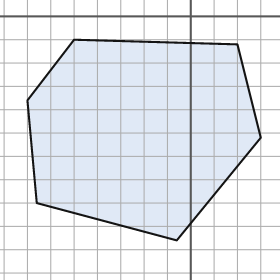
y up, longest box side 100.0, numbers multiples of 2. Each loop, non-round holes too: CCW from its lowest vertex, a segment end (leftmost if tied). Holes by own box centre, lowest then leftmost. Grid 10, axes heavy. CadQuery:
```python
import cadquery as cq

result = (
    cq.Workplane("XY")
    .moveTo(-6.0, -96.0)
    .lineTo(30.0, -52.0)
    .lineTo(20.0, -12.0)
    .lineTo(-50.0, -10.0)
    .lineTo(-70.0, -36.0)
    .lineTo(-66.0, -80.0)
    .close()
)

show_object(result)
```